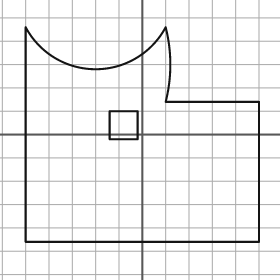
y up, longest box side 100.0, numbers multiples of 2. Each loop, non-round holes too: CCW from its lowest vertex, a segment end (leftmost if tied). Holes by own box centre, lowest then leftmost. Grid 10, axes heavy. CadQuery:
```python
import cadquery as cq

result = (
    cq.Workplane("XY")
    .moveTo(-50.0, -46.0)
    .lineTo(50.0, -46.0)
    .lineTo(50.0, 14.0)
    .lineTo(10.0, 14.0)
    .threePointArc((12.0, 30.0), (10.0, 46.0))
    .threePointArc((-20.0, 28.0), (-50.0, 46.0))
    .close()
    .moveTo(-14.0, -2.0)
    .lineTo(-2.0, -2.0)
    .lineTo(-2.0, 10.0)
    .lineTo(-14.0, 10.0)
    .close()
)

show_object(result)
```